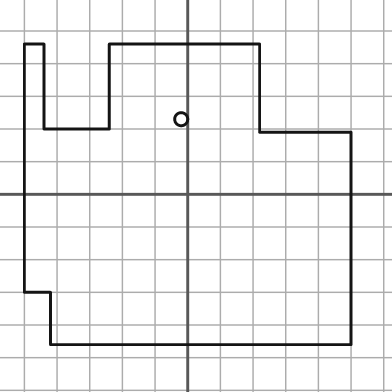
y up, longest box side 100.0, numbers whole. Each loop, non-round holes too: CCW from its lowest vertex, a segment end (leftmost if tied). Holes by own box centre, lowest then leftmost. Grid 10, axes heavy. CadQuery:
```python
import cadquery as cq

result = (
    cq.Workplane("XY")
    .moveTo(-42.0, -46.0)
    .lineTo(50.0, -46.0)
    .lineTo(50.0, 19.0)
    .lineTo(22.0, 19.0)
    .lineTo(22.0, 46.0)
    .lineTo(-24.0, 46.0)
    .lineTo(-24.0, 20.0)
    .lineTo(-44.0, 20.0)
    .lineTo(-44.0, 46.0)
    .lineTo(-50.0, 46.0)
    .lineTo(-50.0, -30.0)
    .lineTo(-42.0, -30.0)
    .close()
    .moveTo(-2.0, 23.0)
    .circle(2.0)
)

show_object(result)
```